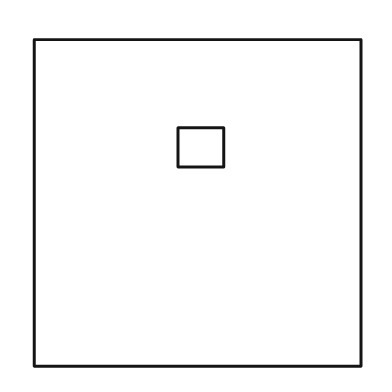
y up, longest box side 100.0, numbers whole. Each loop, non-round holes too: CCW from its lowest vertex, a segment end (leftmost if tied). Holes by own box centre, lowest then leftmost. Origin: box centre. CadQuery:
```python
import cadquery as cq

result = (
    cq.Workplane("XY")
    .moveTo(-50.0, -50.0)
    .lineTo(50.0, -50.0)
    .lineTo(50.0, 50.0)
    .lineTo(-50.0, 50.0)
    .close()
    .moveTo(-6.0, 11.0)
    .lineTo(8.0, 11.0)
    .lineTo(8.0, 23.0)
    .lineTo(-6.0, 23.0)
    .close()
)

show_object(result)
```